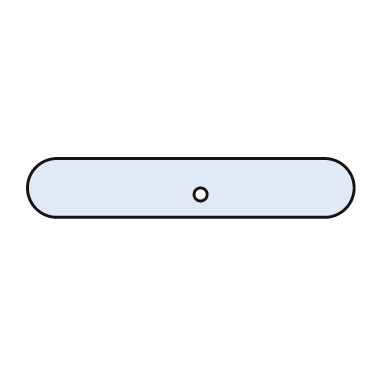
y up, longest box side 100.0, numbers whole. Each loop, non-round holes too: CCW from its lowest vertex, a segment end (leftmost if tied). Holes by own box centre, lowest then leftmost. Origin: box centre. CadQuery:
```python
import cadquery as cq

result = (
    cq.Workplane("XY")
    .moveTo(-41.0, -9.0)
    .lineTo(41.0, -9.0)
    .threePointArc((50.0, 0.0), (41.0, 9.0))
    .lineTo(-41.0, 9.0)
    .threePointArc((-50.0, 0.0), (-41.0, -9.0))
    .close()
    .moveTo(3.0, -2.0)
    .circle(2.0)
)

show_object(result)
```